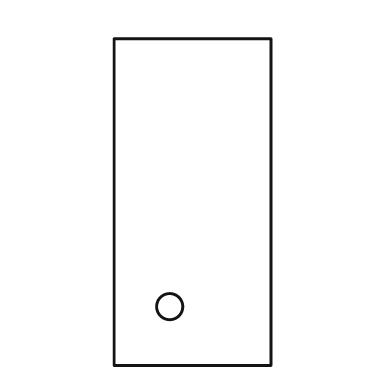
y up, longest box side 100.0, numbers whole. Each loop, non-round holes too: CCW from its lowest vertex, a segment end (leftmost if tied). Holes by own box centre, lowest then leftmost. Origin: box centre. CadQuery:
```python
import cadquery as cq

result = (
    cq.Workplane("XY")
    .moveTo(-24.0, -50.0)
    .lineTo(24.0, -50.0)
    .lineTo(24.0, 50.0)
    .lineTo(-24.0, 50.0)
    .close()
    .moveTo(-7.0, -32.0)
    .circle(4.0)
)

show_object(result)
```